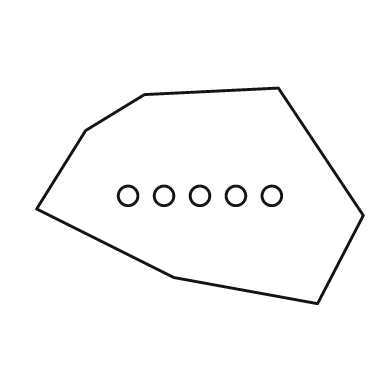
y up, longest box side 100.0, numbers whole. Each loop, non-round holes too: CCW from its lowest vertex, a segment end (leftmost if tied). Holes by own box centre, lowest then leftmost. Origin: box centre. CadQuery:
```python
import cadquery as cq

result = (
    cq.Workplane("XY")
    .moveTo(36.0, -33.0)
    .lineTo(50.0, -6.0)
    .lineTo(24.0, 33.0)
    .lineTo(-17.0, 31.0)
    .lineTo(-35.0, 20.0)
    .lineTo(-50.0, -4.0)
    .lineTo(-8.0, -25.0)
    .close()
    .moveTo(-22.0, 0.0)
    .circle(3.0)
    .moveTo(-11.0, 0.0)
    .circle(3.0)
    .moveTo(0.0, 0.0)
    .circle(3.0)
    .moveTo(11.0, 0.0)
    .circle(3.0)
    .moveTo(22.0, 0.0)
    .circle(3.0)
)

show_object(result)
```